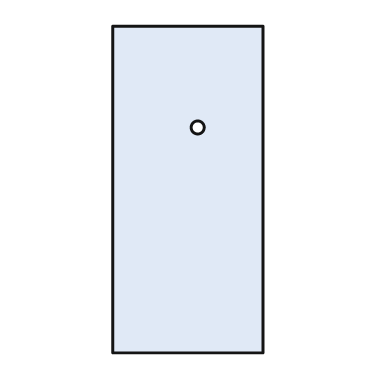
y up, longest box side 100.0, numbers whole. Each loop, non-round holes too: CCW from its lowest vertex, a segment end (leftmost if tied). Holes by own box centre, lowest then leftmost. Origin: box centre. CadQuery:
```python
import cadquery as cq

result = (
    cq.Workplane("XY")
    .moveTo(-23.0, -50.0)
    .lineTo(23.0, -50.0)
    .lineTo(23.0, 50.0)
    .lineTo(-23.0, 50.0)
    .close()
    .moveTo(3.0, 19.0)
    .circle(2.0)
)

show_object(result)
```